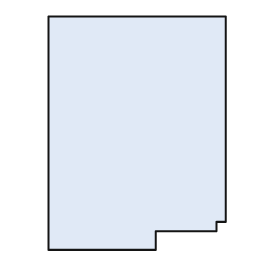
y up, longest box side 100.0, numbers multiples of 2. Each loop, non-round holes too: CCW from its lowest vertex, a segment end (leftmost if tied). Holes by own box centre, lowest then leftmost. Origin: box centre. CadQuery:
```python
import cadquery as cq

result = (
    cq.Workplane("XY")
    .moveTo(-38.0, -50.0)
    .lineTo(8.0, -50.0)
    .lineTo(8.0, -42.0)
    .lineTo(34.0, -42.0)
    .lineTo(34.0, -38.0)
    .lineTo(38.0, -38.0)
    .lineTo(38.0, 50.0)
    .lineTo(-38.0, 50.0)
    .close()
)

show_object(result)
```